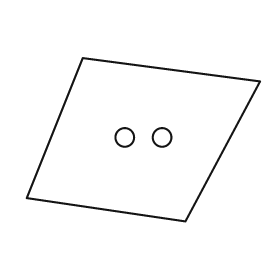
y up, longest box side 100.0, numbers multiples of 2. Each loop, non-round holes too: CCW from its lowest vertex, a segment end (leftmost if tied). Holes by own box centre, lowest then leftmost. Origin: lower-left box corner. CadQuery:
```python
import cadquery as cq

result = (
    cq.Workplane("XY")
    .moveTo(68.0, 0.0)
    .lineTo(100.0, 60.0)
    .lineTo(24.0, 70.0)
    .lineTo(0.0, 10.0)
    .close()
    .moveTo(42.0, 36.0)
    .circle(4.0)
    .moveTo(58.0, 36.0)
    .circle(4.0)
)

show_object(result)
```